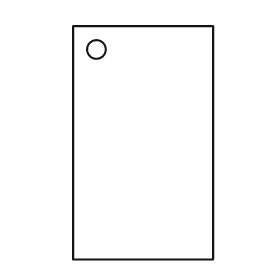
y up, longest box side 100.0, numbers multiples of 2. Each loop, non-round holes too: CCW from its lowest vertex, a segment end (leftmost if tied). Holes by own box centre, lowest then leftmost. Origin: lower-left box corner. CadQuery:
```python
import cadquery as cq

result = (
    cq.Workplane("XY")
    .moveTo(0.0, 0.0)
    .lineTo(60.0, 0.0)
    .lineTo(60.0, 100.0)
    .lineTo(0.0, 100.0)
    .close()
    .moveTo(10.0, 90.0)
    .circle(4.0)
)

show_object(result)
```